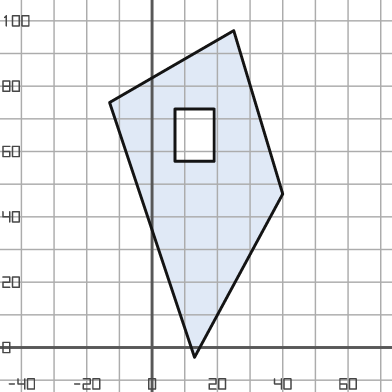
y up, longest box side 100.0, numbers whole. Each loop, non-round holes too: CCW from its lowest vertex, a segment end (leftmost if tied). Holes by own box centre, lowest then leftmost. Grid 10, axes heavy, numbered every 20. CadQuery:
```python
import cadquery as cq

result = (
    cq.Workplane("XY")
    .moveTo(13.0, -3.0)
    .lineTo(40.0, 47.0)
    .lineTo(25.0, 97.0)
    .lineTo(-13.0, 75.0)
    .close()
    .moveTo(7.0, 57.0)
    .lineTo(19.0, 57.0)
    .lineTo(19.0, 73.0)
    .lineTo(7.0, 73.0)
    .close()
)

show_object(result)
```